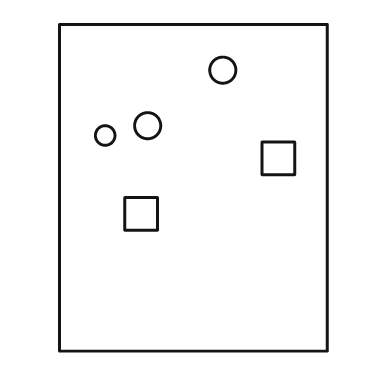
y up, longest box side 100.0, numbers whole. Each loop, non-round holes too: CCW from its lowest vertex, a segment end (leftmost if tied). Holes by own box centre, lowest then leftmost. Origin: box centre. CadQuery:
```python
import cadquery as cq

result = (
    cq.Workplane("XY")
    .moveTo(-41.0, -50.0)
    .lineTo(41.0, -50.0)
    .lineTo(41.0, 50.0)
    .lineTo(-41.0, 50.0)
    .close()
    .moveTo(-21.0, -13.0)
    .lineTo(-11.0, -13.0)
    .lineTo(-11.0, -3.0)
    .lineTo(-21.0, -3.0)
    .close()
    .moveTo(21.0, 4.0)
    .lineTo(31.0, 4.0)
    .lineTo(31.0, 14.0)
    .lineTo(21.0, 14.0)
    .close()
    .moveTo(-27.0, 16.0)
    .circle(3.0)
    .moveTo(-14.0, 19.0)
    .circle(4.0)
    .moveTo(9.0, 36.0)
    .circle(4.0)
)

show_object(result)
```